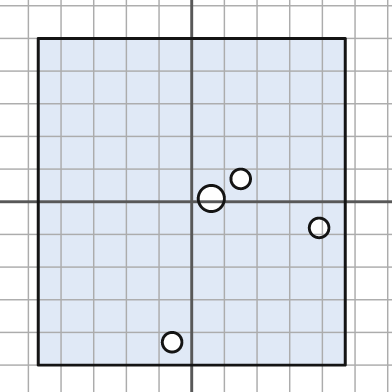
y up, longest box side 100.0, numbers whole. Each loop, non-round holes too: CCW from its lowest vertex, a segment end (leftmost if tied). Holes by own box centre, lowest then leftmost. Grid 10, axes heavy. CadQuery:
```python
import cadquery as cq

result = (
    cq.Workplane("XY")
    .moveTo(-47.0, -50.0)
    .lineTo(47.0, -50.0)
    .lineTo(47.0, 50.0)
    .lineTo(-47.0, 50.0)
    .close()
    .moveTo(-6.0, -43.0)
    .circle(3.0)
    .moveTo(39.0, -8.0)
    .circle(3.0)
    .moveTo(6.0, 1.0)
    .circle(4.0)
    .moveTo(15.0, 7.0)
    .circle(3.0)
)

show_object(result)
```